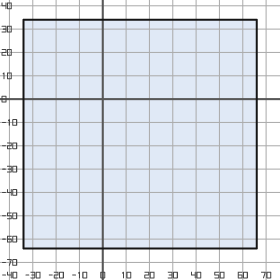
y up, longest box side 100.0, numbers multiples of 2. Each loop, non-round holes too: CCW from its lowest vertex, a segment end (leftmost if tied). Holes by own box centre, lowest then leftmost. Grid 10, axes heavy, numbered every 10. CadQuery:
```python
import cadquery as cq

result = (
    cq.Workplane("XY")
    .moveTo(-34.0, -64.0)
    .lineTo(66.0, -64.0)
    .lineTo(66.0, 34.0)
    .lineTo(-34.0, 34.0)
    .close()
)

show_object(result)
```